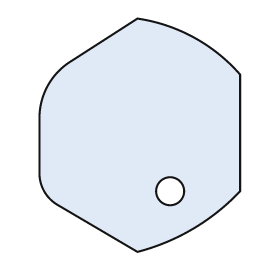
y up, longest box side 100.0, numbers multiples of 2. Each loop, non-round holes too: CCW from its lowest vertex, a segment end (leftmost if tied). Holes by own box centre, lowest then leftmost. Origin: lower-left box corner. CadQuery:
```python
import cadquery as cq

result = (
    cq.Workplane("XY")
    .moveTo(42.0, 0.0)
    .threePointArc((66.0, 10.0), (86.0, 26.0))
    .lineTo(86.0, 76.0)
    .threePointArc((66.0, 92.0), (42.0, 100.0))
    .lineTo(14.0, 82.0)
    .threePointArc((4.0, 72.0), (0.0, 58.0))
    .lineTo(0.0, 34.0)
    .threePointArc((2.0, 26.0), (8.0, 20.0))
    .close()
    .moveTo(56.0, 26.0)
    .circle(6.0)
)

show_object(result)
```